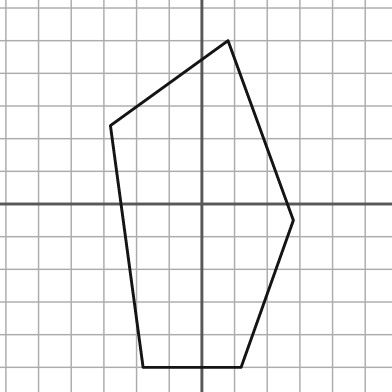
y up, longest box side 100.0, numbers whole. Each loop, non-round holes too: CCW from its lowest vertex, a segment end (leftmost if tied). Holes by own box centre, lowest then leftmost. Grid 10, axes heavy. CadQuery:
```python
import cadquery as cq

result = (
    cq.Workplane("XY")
    .moveTo(-18.0, -50.0)
    .lineTo(12.0, -50.0)
    .lineTo(28.0, -5.0)
    .lineTo(8.0, 50.0)
    .lineTo(-28.0, 24.0)
    .close()
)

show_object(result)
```